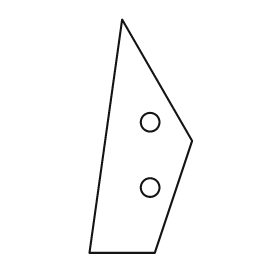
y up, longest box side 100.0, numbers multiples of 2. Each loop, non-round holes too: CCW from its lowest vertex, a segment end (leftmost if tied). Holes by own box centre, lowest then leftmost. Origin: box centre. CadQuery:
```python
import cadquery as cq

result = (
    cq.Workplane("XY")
    .moveTo(-22.0, -50.0)
    .lineTo(6.0, -50.0)
    .lineTo(22.0, -2.0)
    .lineTo(-8.0, 50.0)
    .close()
    .moveTo(4.0, -22.0)
    .circle(4.0)
    .moveTo(4.0, 6.0)
    .circle(4.0)
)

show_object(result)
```